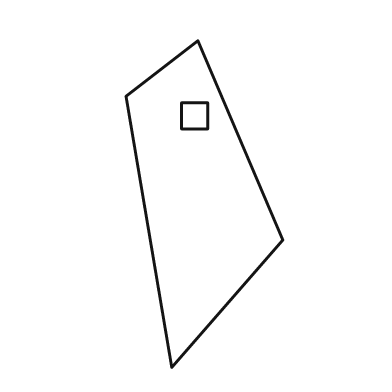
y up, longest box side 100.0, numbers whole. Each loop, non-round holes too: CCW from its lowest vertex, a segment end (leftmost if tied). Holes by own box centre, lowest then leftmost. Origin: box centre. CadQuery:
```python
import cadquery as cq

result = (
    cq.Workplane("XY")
    .moveTo(-10.0, -50.0)
    .lineTo(24.0, -11.0)
    .lineTo(-2.0, 50.0)
    .lineTo(-24.0, 33.0)
    .close()
    .moveTo(-7.0, 23.0)
    .lineTo(1.0, 23.0)
    .lineTo(1.0, 31.0)
    .lineTo(-7.0, 31.0)
    .close()
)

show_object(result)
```